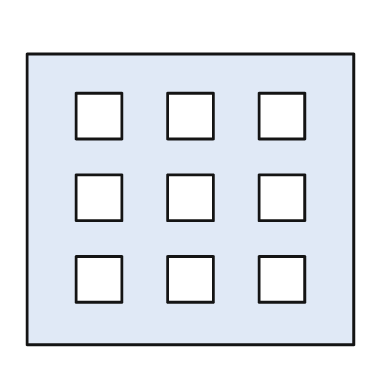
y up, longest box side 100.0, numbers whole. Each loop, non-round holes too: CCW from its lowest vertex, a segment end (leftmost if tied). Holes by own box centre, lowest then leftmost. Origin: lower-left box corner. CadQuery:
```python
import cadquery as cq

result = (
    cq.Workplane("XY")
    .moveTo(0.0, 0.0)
    .lineTo(100.0, 0.0)
    .lineTo(100.0, 89.0)
    .lineTo(0.0, 89.0)
    .close()
    .moveTo(15.0, 13.0)
    .lineTo(29.0, 13.0)
    .lineTo(29.0, 27.0)
    .lineTo(15.0, 27.0)
    .close()
    .moveTo(43.0, 13.0)
    .lineTo(57.0, 13.0)
    .lineTo(57.0, 27.0)
    .lineTo(43.0, 27.0)
    .close()
    .moveTo(71.0, 13.0)
    .lineTo(85.0, 13.0)
    .lineTo(85.0, 27.0)
    .lineTo(71.0, 27.0)
    .close()
    .moveTo(15.0, 38.0)
    .lineTo(29.0, 38.0)
    .lineTo(29.0, 52.0)
    .lineTo(15.0, 52.0)
    .close()
    .moveTo(43.0, 38.0)
    .lineTo(57.0, 38.0)
    .lineTo(57.0, 52.0)
    .lineTo(43.0, 52.0)
    .close()
    .moveTo(71.0, 38.0)
    .lineTo(85.0, 38.0)
    .lineTo(85.0, 52.0)
    .lineTo(71.0, 52.0)
    .close()
    .moveTo(15.0, 63.0)
    .lineTo(29.0, 63.0)
    .lineTo(29.0, 77.0)
    .lineTo(15.0, 77.0)
    .close()
    .moveTo(43.0, 63.0)
    .lineTo(57.0, 63.0)
    .lineTo(57.0, 77.0)
    .lineTo(43.0, 77.0)
    .close()
    .moveTo(71.0, 63.0)
    .lineTo(85.0, 63.0)
    .lineTo(85.0, 77.0)
    .lineTo(71.0, 77.0)
    .close()
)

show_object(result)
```